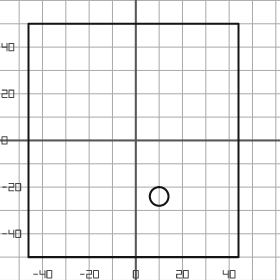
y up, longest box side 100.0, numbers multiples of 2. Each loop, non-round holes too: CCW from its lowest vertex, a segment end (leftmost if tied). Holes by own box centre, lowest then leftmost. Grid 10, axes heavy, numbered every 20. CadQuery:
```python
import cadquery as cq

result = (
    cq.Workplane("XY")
    .moveTo(-46.0, -50.0)
    .lineTo(44.0, -50.0)
    .lineTo(44.0, 50.0)
    .lineTo(-46.0, 50.0)
    .close()
    .moveTo(10.0, -24.0)
    .circle(4.0)
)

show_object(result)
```